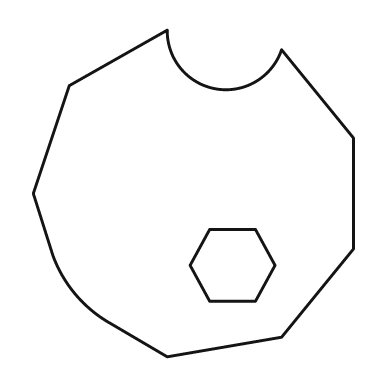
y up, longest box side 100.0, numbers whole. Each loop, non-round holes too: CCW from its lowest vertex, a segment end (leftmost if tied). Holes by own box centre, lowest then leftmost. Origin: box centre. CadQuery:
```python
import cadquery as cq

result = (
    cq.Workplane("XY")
    .moveTo(-8.0, -50.0)
    .lineTo(27.0, -44.0)
    .lineTo(49.0, -17.0)
    .lineTo(49.0, 17.0)
    .lineTo(27.0, 44.0)
    .threePointArc((7.0, 32.0), (-8.0, 50.0))
    .lineTo(-38.0, 33.0)
    .lineTo(-49.0, 0.0)
    .lineTo(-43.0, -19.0)
    .threePointArc((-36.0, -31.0), (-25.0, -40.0))
    .close()
    .moveTo(5.0, -33.0)
    .lineTo(19.0, -33.0)
    .lineTo(25.0, -22.0)
    .lineTo(19.0, -11.0)
    .lineTo(5.0, -11.0)
    .lineTo(-1.0, -22.0)
    .close()
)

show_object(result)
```